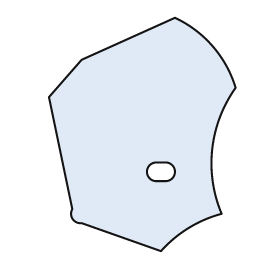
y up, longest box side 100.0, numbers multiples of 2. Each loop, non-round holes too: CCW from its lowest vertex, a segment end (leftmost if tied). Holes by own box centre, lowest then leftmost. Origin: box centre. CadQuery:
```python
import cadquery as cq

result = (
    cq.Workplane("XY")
    .moveTo(8.0, -50.0)
    .threePointArc((20.0, -40.0), (34.0, -34.0))
    .threePointArc((30.0, -6.0), (40.0, 20.0))
    .threePointArc((30.0, 38.0), (14.0, 50.0))
    .lineTo(-26.0, 32.0)
    .lineTo(-40.0, 16.0)
    .lineTo(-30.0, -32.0)
    .threePointArc((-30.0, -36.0), (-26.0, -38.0))
    .close()
    .moveTo(6.0, -20.0)
    .lineTo(10.0, -20.0)
    .threePointArc((14.0, -16.0), (10.0, -12.0))
    .lineTo(6.0, -12.0)
    .threePointArc((2.0, -16.0), (6.0, -20.0))
    .close()
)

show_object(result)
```